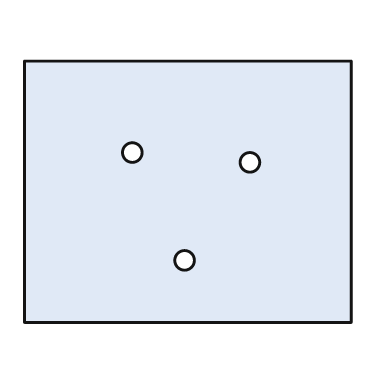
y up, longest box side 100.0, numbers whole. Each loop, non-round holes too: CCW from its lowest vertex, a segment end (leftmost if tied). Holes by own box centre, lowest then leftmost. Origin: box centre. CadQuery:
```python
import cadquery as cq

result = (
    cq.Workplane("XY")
    .moveTo(-50.0, -40.0)
    .lineTo(50.0, -40.0)
    .lineTo(50.0, 40.0)
    .lineTo(-50.0, 40.0)
    .close()
    .moveTo(-1.0, -21.0)
    .circle(3.0)
    .moveTo(19.0, 9.0)
    .circle(3.0)
    .moveTo(-17.0, 12.0)
    .circle(3.0)
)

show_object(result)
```